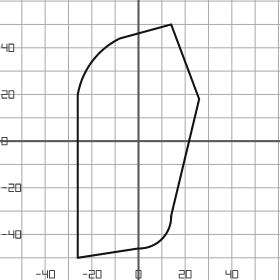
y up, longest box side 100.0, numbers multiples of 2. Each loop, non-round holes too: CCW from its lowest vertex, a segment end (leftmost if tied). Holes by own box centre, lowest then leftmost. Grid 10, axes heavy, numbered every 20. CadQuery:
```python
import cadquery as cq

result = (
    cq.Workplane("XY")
    .moveTo(-26.0, -50.0)
    .lineTo(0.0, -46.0)
    .threePointArc((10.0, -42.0), (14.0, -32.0))
    .lineTo(26.0, 18.0)
    .lineTo(14.0, 50.0)
    .lineTo(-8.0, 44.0)
    .threePointArc((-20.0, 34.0), (-26.0, 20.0))
    .close()
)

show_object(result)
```